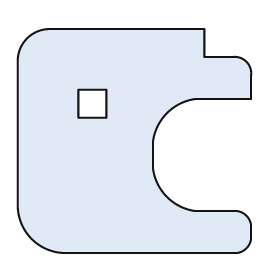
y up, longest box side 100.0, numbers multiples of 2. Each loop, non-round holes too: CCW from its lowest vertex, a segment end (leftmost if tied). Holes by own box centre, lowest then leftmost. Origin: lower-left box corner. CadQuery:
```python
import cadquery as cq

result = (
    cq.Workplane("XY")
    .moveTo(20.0, 0.0)
    .lineTo(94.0, 0.0)
    .threePointArc((98.0, 2.0), (100.0, 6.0))
    .lineTo(100.0, 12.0)
    .threePointArc((98.0, 16.0), (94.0, 18.0))
    .lineTo(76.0, 18.0)
    .threePointArc((64.0, 24.0), (58.0, 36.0))
    .lineTo(58.0, 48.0)
    .threePointArc((64.0, 60.0), (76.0, 66.0))
    .lineTo(100.0, 66.0)
    .lineTo(100.0, 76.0)
    .threePointArc((98.0, 82.0), (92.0, 84.0))
    .lineTo(80.0, 84.0)
    .lineTo(80.0, 96.0)
    .lineTo(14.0, 96.0)
    .threePointArc((4.0, 92.0), (0.0, 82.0))
    .lineTo(0.0, 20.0)
    .threePointArc((6.0, 6.0), (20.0, 0.0))
    .close()
    .moveTo(26.0, 58.0)
    .lineTo(38.0, 58.0)
    .lineTo(38.0, 70.0)
    .lineTo(26.0, 70.0)
    .close()
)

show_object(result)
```